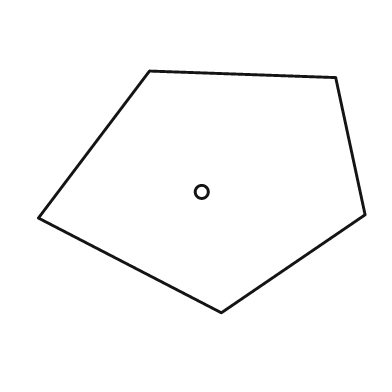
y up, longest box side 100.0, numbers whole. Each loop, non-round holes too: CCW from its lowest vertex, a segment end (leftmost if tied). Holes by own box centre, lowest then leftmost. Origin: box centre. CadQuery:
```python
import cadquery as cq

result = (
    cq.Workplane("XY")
    .moveTo(6.0, -37.0)
    .lineTo(50.0, -7.0)
    .lineTo(41.0, 35.0)
    .lineTo(-16.0, 37.0)
    .lineTo(-50.0, -8.0)
    .close()
    .moveTo(0.0, 0.0)
    .circle(2.0)
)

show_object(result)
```